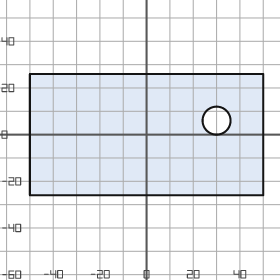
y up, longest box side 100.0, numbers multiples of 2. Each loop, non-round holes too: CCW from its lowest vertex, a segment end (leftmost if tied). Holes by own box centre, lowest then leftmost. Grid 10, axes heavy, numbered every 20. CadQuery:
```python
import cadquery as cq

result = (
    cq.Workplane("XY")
    .moveTo(-50.0, -26.0)
    .lineTo(50.0, -26.0)
    .lineTo(50.0, 26.0)
    .lineTo(-50.0, 26.0)
    .close()
    .moveTo(30.0, 6.0)
    .circle(6.0)
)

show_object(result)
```